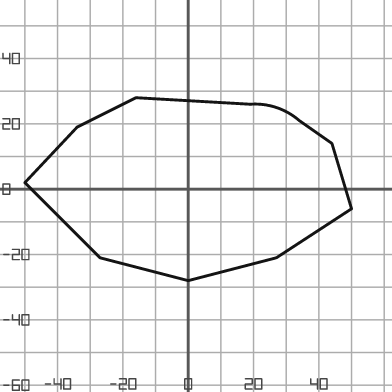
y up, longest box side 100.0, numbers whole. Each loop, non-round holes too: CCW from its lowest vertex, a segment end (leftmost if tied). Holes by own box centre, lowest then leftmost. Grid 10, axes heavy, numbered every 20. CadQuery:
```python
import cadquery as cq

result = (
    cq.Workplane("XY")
    .moveTo(0.0, -28.0)
    .lineTo(27.0, -21.0)
    .lineTo(50.0, -6.0)
    .lineTo(44.0, 14.0)
    .lineTo(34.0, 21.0)
    .threePointArc((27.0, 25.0), (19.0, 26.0))
    .lineTo(-16.0, 28.0)
    .lineTo(-34.0, 19.0)
    .lineTo(-50.0, 2.0)
    .lineTo(-27.0, -21.0)
    .close()
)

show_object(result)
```